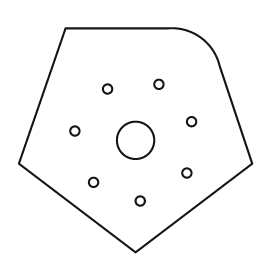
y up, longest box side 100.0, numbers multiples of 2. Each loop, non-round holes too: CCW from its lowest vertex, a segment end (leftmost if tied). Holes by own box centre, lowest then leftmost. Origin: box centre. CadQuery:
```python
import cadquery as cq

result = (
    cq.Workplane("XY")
    .moveTo(0.0, -48.0)
    .lineTo(50.0, -10.0)
    .lineTo(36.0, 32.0)
    .threePointArc((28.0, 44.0), (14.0, 48.0))
    .lineTo(-30.0, 48.0)
    .lineTo(-50.0, -10.0)
    .close()
    .moveTo(2.0, -26.0)
    .circle(2.0)
    .moveTo(-18.0, -18.0)
    .circle(2.0)
    .moveTo(22.0, -14.0)
    .circle(2.0)
    .moveTo(0.0, 0.0)
    .circle(8.0)
    .moveTo(-26.0, 4.0)
    .circle(2.0)
    .moveTo(24.0, 8.0)
    .circle(2.0)
    .moveTo(-12.0, 22.0)
    .circle(2.0)
    .moveTo(10.0, 24.0)
    .circle(2.0)
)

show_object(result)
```